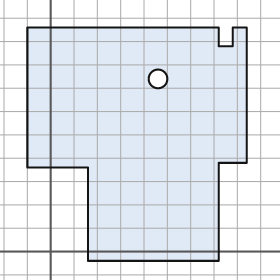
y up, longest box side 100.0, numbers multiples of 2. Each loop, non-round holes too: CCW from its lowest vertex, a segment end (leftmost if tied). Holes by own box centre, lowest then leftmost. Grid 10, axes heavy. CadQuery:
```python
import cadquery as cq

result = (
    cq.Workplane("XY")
    .moveTo(16.0, -4.0)
    .lineTo(72.0, -4.0)
    .lineTo(72.0, 38.0)
    .lineTo(84.0, 38.0)
    .lineTo(84.0, 96.0)
    .lineTo(78.0, 96.0)
    .lineTo(78.0, 88.0)
    .lineTo(72.0, 88.0)
    .lineTo(72.0, 96.0)
    .lineTo(-10.0, 96.0)
    .lineTo(-10.0, 36.0)
    .lineTo(16.0, 36.0)
    .close()
    .moveTo(46.0, 74.0)
    .circle(4.0)
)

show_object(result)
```